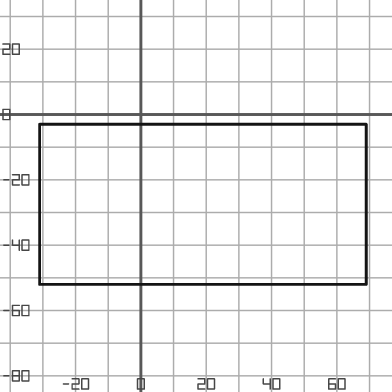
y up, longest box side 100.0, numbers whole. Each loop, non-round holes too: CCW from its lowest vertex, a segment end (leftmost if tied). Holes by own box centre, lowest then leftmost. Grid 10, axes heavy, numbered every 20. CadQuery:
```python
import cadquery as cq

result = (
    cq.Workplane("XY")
    .moveTo(-31.0, -52.0)
    .lineTo(69.0, -52.0)
    .lineTo(69.0, -3.0)
    .lineTo(-31.0, -3.0)
    .close()
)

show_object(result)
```